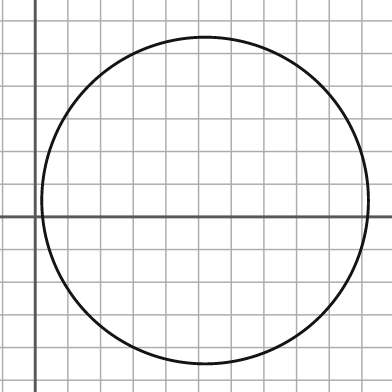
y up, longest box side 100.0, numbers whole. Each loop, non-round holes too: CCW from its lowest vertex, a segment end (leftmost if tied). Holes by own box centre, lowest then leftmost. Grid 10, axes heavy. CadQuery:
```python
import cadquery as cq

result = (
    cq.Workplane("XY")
    .moveTo(52.0, 5.0)
    .circle(50.0)
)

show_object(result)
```